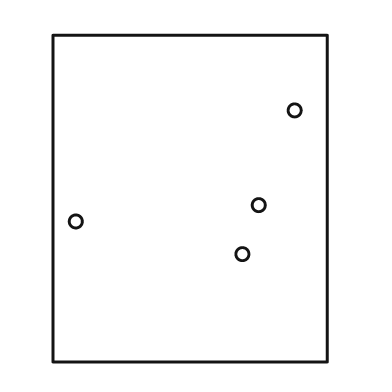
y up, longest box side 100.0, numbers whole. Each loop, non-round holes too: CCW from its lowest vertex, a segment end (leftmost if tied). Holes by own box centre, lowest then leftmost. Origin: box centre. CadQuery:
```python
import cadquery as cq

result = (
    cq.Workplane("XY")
    .moveTo(-42.0, -50.0)
    .lineTo(42.0, -50.0)
    .lineTo(42.0, 50.0)
    .lineTo(-42.0, 50.0)
    .close()
    .moveTo(16.0, -17.0)
    .circle(2.0)
    .moveTo(-35.0, -7.0)
    .circle(2.0)
    .moveTo(21.0, -2.0)
    .circle(2.0)
    .moveTo(32.0, 27.0)
    .circle(2.0)
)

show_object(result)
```